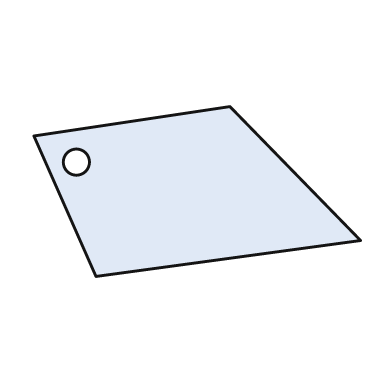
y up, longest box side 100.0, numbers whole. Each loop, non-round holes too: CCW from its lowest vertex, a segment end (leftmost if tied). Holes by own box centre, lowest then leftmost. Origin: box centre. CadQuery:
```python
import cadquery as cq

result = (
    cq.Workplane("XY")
    .moveTo(-31.0, -26.0)
    .lineTo(50.0, -15.0)
    .lineTo(10.0, 26.0)
    .lineTo(-50.0, 17.0)
    .close()
    .moveTo(-37.0, 9.0)
    .circle(4.0)
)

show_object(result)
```